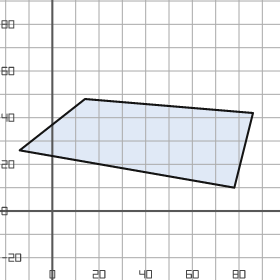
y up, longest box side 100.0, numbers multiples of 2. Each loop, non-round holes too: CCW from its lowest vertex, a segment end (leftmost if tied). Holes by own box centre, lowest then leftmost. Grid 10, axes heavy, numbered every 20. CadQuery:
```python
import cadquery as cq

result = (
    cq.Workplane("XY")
    .moveTo(78.0, 10.0)
    .lineTo(86.0, 42.0)
    .lineTo(14.0, 48.0)
    .lineTo(-14.0, 26.0)
    .close()
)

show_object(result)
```